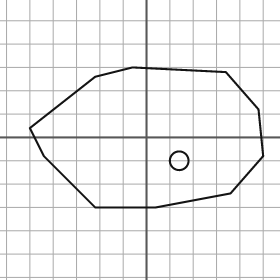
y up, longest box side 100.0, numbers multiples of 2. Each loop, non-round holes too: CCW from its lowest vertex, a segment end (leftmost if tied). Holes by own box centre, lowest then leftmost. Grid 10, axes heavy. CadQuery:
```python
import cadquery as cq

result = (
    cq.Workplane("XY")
    .moveTo(-22.0, -30.0)
    .lineTo(4.0, -30.0)
    .lineTo(36.0, -24.0)
    .lineTo(50.0, -8.0)
    .lineTo(48.0, 12.0)
    .lineTo(34.0, 28.0)
    .lineTo(-6.0, 30.0)
    .lineTo(-22.0, 26.0)
    .lineTo(-50.0, 4.0)
    .lineTo(-44.0, -8.0)
    .close()
    .moveTo(14.0, -10.0)
    .circle(4.0)
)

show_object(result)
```